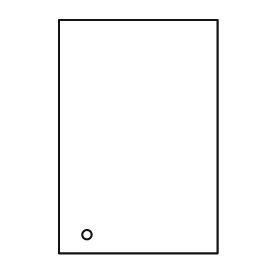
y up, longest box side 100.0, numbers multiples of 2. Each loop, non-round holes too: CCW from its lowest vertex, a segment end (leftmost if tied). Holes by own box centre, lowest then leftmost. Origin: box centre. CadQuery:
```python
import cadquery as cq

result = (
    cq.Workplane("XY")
    .moveTo(-34.0, -50.0)
    .lineTo(34.0, -50.0)
    .lineTo(34.0, 50.0)
    .lineTo(-34.0, 50.0)
    .close()
    .moveTo(-22.0, -42.0)
    .circle(2.0)
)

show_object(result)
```